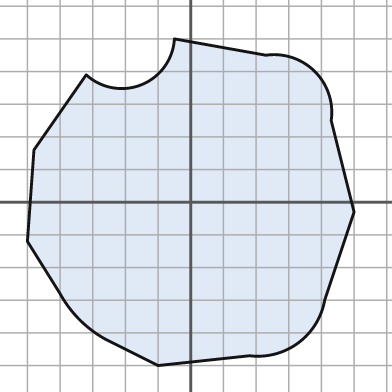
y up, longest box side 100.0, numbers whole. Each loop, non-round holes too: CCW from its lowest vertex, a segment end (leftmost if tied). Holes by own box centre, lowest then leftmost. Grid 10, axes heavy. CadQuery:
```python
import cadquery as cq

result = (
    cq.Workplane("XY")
    .moveTo(-10.0, -50.0)
    .lineTo(18.0, -47.0)
    .threePointArc((33.0, -43.0), (41.0, -30.0))
    .lineTo(50.0, -3.0)
    .lineTo(43.0, 25.0)
    .threePointArc((38.0, 40.0), (23.0, 45.0))
    .lineTo(-5.0, 50.0)
    .threePointArc((-15.0, 36.0), (-32.0, 39.0))
    .lineTo(-48.0, 16.0)
    .lineTo(-50.0, -12.0)
    .lineTo(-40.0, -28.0)
    .threePointArc((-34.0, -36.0), (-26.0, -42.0))
    .close()
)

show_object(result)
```